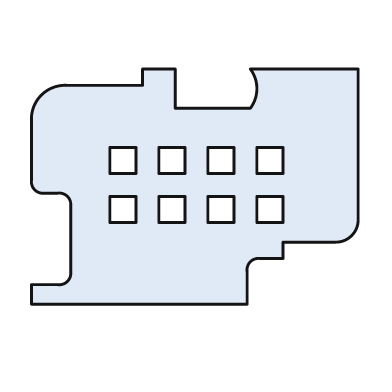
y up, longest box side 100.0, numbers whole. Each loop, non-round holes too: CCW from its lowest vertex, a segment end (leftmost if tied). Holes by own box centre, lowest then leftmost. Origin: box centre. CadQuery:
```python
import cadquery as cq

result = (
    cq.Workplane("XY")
    .moveTo(-50.0, -36.0)
    .lineTo(16.0, -36.0)
    .lineTo(16.0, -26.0)
    .threePointArc((17.0, -23.0), (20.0, -22.0))
    .lineTo(27.0, -22.0)
    .lineTo(27.0, -17.0)
    .lineTo(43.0, -17.0)
    .threePointArc((48.0, -15.0), (50.0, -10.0))
    .lineTo(50.0, 36.0)
    .lineTo(17.0, 36.0)
    .threePointArc((19.0, 30.0), (17.0, 24.0))
    .lineTo(-6.0, 24.0)
    .lineTo(-6.0, 36.0)
    .lineTo(-16.0, 36.0)
    .lineTo(-16.0, 31.0)
    .lineTo(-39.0, 31.0)
    .threePointArc((-47.0, 28.0), (-50.0, 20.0))
    .lineTo(-50.0, 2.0)
    .threePointArc((-49.0, -1.0), (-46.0, -2.0))
    .lineTo(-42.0, -2.0)
    .threePointArc((-39.0, -3.0), (-38.0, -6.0))
    .lineTo(-38.0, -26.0)
    .threePointArc((-39.0, -29.0), (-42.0, -30.0))
    .lineTo(-50.0, -30.0)
    .close()
    .moveTo(-26.0, -11.0)
    .lineTo(-18.0, -11.0)
    .lineTo(-18.0, -3.0)
    .lineTo(-26.0, -3.0)
    .close()
    .moveTo(-11.0, -11.0)
    .lineTo(-3.0, -11.0)
    .lineTo(-3.0, -3.0)
    .lineTo(-11.0, -3.0)
    .close()
    .moveTo(4.0, -11.0)
    .lineTo(12.0, -11.0)
    .lineTo(12.0, -3.0)
    .lineTo(4.0, -3.0)
    .close()
    .moveTo(19.0, -11.0)
    .lineTo(27.0, -11.0)
    .lineTo(27.0, -3.0)
    .lineTo(19.0, -3.0)
    .close()
    .moveTo(-26.0, 4.0)
    .lineTo(-18.0, 4.0)
    .lineTo(-18.0, 12.0)
    .lineTo(-26.0, 12.0)
    .close()
    .moveTo(-11.0, 4.0)
    .lineTo(-3.0, 4.0)
    .lineTo(-3.0, 12.0)
    .lineTo(-11.0, 12.0)
    .close()
    .moveTo(4.0, 4.0)
    .lineTo(12.0, 4.0)
    .lineTo(12.0, 12.0)
    .lineTo(4.0, 12.0)
    .close()
    .moveTo(19.0, 4.0)
    .lineTo(27.0, 4.0)
    .lineTo(27.0, 12.0)
    .lineTo(19.0, 12.0)
    .close()
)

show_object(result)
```